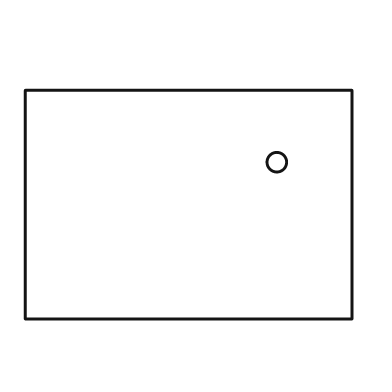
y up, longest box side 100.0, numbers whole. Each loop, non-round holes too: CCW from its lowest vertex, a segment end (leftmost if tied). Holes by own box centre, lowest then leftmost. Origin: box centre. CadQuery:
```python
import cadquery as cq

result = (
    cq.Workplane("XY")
    .moveTo(-50.0, -35.0)
    .lineTo(50.0, -35.0)
    .lineTo(50.0, 35.0)
    .lineTo(-50.0, 35.0)
    .close()
    .moveTo(27.0, 13.0)
    .circle(3.0)
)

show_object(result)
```